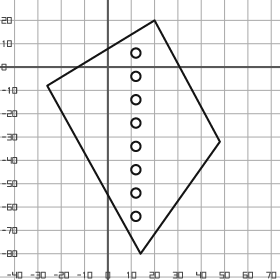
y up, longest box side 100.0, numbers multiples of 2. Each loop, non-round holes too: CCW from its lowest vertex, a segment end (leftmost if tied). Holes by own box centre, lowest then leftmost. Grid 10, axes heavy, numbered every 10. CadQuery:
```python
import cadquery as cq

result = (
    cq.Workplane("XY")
    .moveTo(14.0, -80.0)
    .lineTo(48.0, -32.0)
    .lineTo(20.0, 20.0)
    .lineTo(-26.0, -8.0)
    .close()
    .moveTo(12.0, -64.0)
    .circle(2.0)
    .moveTo(12.0, -54.0)
    .circle(2.0)
    .moveTo(12.0, -44.0)
    .circle(2.0)
    .moveTo(12.0, -34.0)
    .circle(2.0)
    .moveTo(12.0, -24.0)
    .circle(2.0)
    .moveTo(12.0, -14.0)
    .circle(2.0)
    .moveTo(12.0, -4.0)
    .circle(2.0)
    .moveTo(12.0, 6.0)
    .circle(2.0)
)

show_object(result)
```